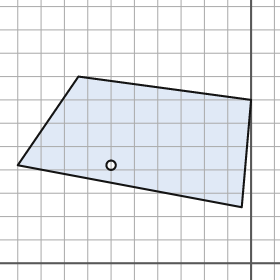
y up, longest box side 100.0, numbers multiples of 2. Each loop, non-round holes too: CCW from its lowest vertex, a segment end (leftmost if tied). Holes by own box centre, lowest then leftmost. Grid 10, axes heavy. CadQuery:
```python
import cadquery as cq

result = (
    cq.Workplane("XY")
    .moveTo(-4.0, 24.0)
    .lineTo(0.0, 70.0)
    .lineTo(-74.0, 80.0)
    .lineTo(-100.0, 42.0)
    .close()
    .moveTo(-60.0, 42.0)
    .circle(2.0)
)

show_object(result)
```